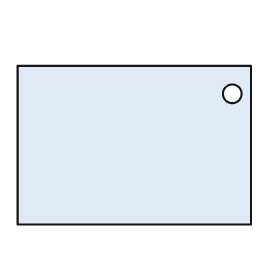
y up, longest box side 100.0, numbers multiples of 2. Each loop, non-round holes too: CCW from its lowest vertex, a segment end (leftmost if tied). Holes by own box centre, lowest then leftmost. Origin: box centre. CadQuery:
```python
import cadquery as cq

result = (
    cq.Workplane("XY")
    .moveTo(-50.0, -34.0)
    .lineTo(50.0, -34.0)
    .lineTo(50.0, 34.0)
    .lineTo(-50.0, 34.0)
    .close()
    .moveTo(42.0, 22.0)
    .circle(4.0)
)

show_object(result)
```